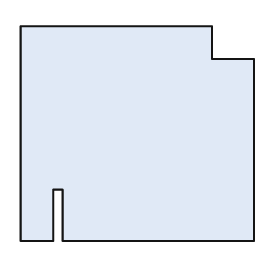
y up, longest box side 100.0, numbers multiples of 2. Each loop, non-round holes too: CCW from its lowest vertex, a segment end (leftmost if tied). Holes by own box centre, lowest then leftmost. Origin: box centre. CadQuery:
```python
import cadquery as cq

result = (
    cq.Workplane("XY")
    .moveTo(-50.0, -46.0)
    .lineTo(-36.0, -46.0)
    .lineTo(-36.0, -24.0)
    .lineTo(-32.0, -24.0)
    .lineTo(-32.0, -46.0)
    .lineTo(50.0, -46.0)
    .lineTo(50.0, 32.0)
    .lineTo(32.0, 32.0)
    .lineTo(32.0, 46.0)
    .lineTo(-50.0, 46.0)
    .close()
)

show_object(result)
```